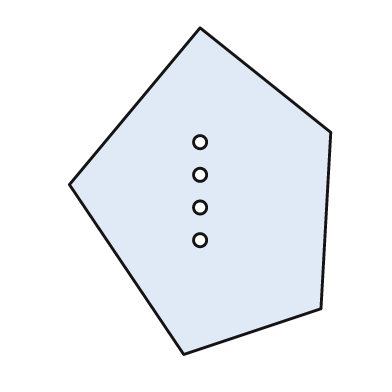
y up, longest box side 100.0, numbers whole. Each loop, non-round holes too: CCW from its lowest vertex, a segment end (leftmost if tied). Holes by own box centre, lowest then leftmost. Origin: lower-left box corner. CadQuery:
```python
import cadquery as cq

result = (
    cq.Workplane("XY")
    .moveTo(35.0, 0.0)
    .lineTo(77.0, 14.0)
    .lineTo(80.0, 68.0)
    .lineTo(40.0, 100.0)
    .lineTo(0.0, 52.0)
    .close()
    .moveTo(40.0, 35.0)
    .circle(2.0)
    .moveTo(40.0, 45.0)
    .circle(2.0)
    .moveTo(40.0, 55.0)
    .circle(2.0)
    .moveTo(40.0, 65.0)
    .circle(2.0)
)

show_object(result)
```